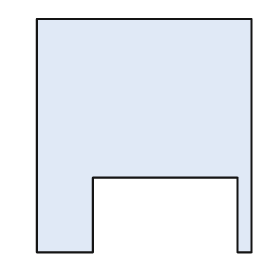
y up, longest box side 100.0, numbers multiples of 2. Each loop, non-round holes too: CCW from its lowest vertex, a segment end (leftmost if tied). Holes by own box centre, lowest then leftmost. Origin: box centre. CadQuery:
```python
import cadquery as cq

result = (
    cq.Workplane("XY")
    .moveTo(-46.0, -50.0)
    .lineTo(-22.0, -50.0)
    .lineTo(-22.0, -18.0)
    .lineTo(40.0, -18.0)
    .lineTo(40.0, -50.0)
    .lineTo(46.0, -50.0)
    .lineTo(46.0, 50.0)
    .lineTo(-46.0, 50.0)
    .close()
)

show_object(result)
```